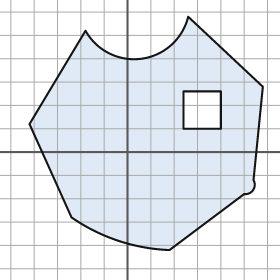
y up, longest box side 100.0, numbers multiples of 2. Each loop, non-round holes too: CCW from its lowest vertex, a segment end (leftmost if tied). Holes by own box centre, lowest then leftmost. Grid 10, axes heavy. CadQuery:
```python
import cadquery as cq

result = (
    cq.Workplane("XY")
    .moveTo(18.0, -42.0)
    .lineTo(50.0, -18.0)
    .threePointArc((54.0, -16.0), (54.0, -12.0))
    .lineTo(58.0, 28.0)
    .lineTo(26.0, 58.0)
    .threePointArc((6.0, 40.0), (-18.0, 52.0))
    .lineTo(-42.0, 12.0)
    .lineTo(-24.0, -28.0)
    .threePointArc((-4.0, -38.0), (18.0, -42.0))
    .close()
    .moveTo(24.0, 10.0)
    .lineTo(40.0, 10.0)
    .lineTo(40.0, 26.0)
    .lineTo(24.0, 26.0)
    .close()
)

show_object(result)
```